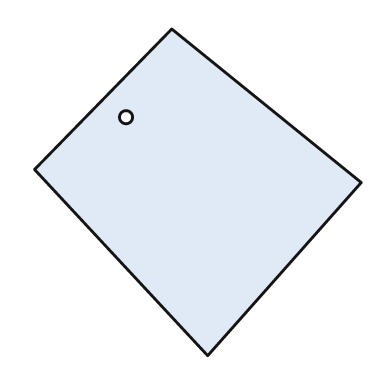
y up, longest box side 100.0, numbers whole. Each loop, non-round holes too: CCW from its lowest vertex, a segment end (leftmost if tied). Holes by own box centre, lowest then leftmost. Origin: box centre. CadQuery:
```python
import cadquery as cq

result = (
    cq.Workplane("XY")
    .moveTo(3.0, -50.0)
    .lineTo(50.0, 3.0)
    .lineTo(-8.0, 50.0)
    .lineTo(-50.0, 7.0)
    .close()
    .moveTo(-22.0, 23.0)
    .circle(2.0)
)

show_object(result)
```